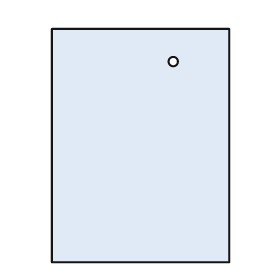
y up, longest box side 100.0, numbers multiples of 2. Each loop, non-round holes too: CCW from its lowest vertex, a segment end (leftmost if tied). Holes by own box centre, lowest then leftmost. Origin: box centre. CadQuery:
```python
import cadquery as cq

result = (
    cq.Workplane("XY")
    .moveTo(-38.0, -50.0)
    .lineTo(38.0, -50.0)
    .lineTo(38.0, 50.0)
    .lineTo(-38.0, 50.0)
    .close()
    .moveTo(14.0, 36.0)
    .circle(2.0)
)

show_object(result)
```